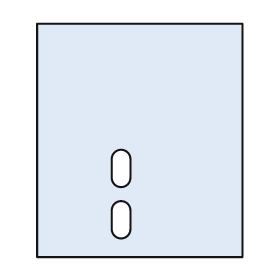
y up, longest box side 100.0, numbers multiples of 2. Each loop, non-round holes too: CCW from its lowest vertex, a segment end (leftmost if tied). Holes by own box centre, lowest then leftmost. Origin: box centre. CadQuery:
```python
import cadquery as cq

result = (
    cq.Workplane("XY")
    .moveTo(-44.0, -50.0)
    .lineTo(44.0, -50.0)
    .lineTo(44.0, 50.0)
    .lineTo(-44.0, 50.0)
    .close()
    .moveTo(-12.0, -38.0)
    .threePointArc((-8.0, -42.0), (-4.0, -38.0))
    .lineTo(-4.0, -30.0)
    .threePointArc((-8.0, -26.0), (-12.0, -30.0))
    .close()
    .moveTo(-12.0, -16.0)
    .threePointArc((-8.0, -20.0), (-4.0, -16.0))
    .lineTo(-4.0, -8.0)
    .threePointArc((-8.0, -4.0), (-12.0, -8.0))
    .close()
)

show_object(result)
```